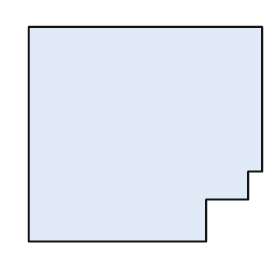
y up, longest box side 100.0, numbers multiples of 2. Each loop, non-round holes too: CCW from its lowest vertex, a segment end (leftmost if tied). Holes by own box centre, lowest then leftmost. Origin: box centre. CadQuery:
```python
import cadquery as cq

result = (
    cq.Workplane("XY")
    .moveTo(-50.0, -46.0)
    .lineTo(26.0, -46.0)
    .lineTo(26.0, -28.0)
    .lineTo(44.0, -28.0)
    .lineTo(44.0, -16.0)
    .lineTo(50.0, -16.0)
    .lineTo(50.0, 46.0)
    .lineTo(-50.0, 46.0)
    .close()
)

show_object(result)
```